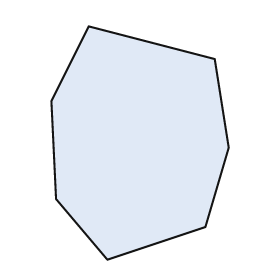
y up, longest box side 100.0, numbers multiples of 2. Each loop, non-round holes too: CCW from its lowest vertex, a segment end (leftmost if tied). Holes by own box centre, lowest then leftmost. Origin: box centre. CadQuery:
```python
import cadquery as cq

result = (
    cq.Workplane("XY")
    .moveTo(-14.0, -50.0)
    .lineTo(28.0, -36.0)
    .lineTo(38.0, -2.0)
    .lineTo(32.0, 36.0)
    .lineTo(-22.0, 50.0)
    .lineTo(-38.0, 18.0)
    .lineTo(-36.0, -24.0)
    .close()
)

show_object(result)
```